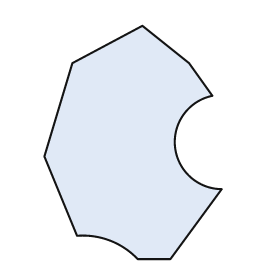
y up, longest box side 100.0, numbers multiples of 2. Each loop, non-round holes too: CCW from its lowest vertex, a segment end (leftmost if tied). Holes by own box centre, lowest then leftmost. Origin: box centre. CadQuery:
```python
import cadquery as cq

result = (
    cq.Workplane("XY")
    .moveTo(2.0, -50.0)
    .lineTo(16.0, -50.0)
    .lineTo(38.0, -20.0)
    .threePointArc((18.0, -2.0), (34.0, 20.0))
    .lineTo(24.0, 34.0)
    .lineTo(4.0, 50.0)
    .lineTo(-26.0, 34.0)
    .lineTo(-38.0, -6.0)
    .lineTo(-24.0, -40.0)
    .threePointArc((-10.0, -42.0), (2.0, -50.0))
    .close()
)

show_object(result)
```